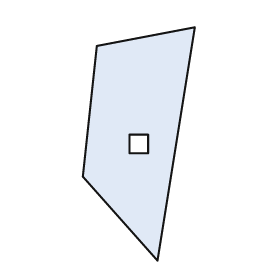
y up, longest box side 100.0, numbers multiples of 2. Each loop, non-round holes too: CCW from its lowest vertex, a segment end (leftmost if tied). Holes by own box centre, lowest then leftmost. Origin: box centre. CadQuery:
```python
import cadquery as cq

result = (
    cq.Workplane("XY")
    .moveTo(8.0, -50.0)
    .lineTo(24.0, 50.0)
    .lineTo(-18.0, 42.0)
    .lineTo(-24.0, -14.0)
    .close()
    .moveTo(-4.0, -4.0)
    .lineTo(4.0, -4.0)
    .lineTo(4.0, 4.0)
    .lineTo(-4.0, 4.0)
    .close()
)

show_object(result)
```